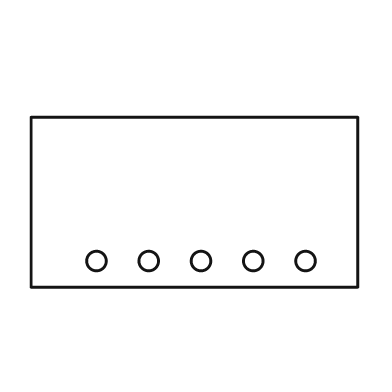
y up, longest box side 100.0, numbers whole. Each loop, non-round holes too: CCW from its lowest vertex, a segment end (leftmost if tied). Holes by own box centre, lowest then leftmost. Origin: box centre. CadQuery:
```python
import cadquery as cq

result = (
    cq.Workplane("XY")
    .moveTo(-50.0, -26.0)
    .lineTo(50.0, -26.0)
    .lineTo(50.0, 26.0)
    .lineTo(-50.0, 26.0)
    .close()
    .moveTo(-30.0, -18.0)
    .circle(3.0)
    .moveTo(-14.0, -18.0)
    .circle(3.0)
    .moveTo(2.0, -18.0)
    .circle(3.0)
    .moveTo(18.0, -18.0)
    .circle(3.0)
    .moveTo(34.0, -18.0)
    .circle(3.0)
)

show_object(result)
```